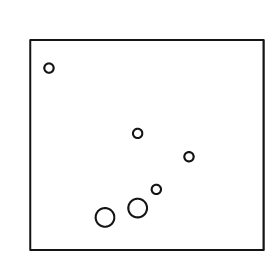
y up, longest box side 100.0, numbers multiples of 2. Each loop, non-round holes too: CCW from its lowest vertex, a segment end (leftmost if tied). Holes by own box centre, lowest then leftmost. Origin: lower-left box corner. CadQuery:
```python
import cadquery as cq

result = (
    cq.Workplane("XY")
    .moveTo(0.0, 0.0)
    .lineTo(100.0, 0.0)
    .lineTo(100.0, 90.0)
    .lineTo(0.0, 90.0)
    .close()
    .moveTo(32.0, 14.0)
    .circle(4.0)
    .moveTo(46.0, 18.0)
    .circle(4.0)
    .moveTo(54.0, 26.0)
    .circle(2.0)
    .moveTo(68.0, 40.0)
    .circle(2.0)
    .moveTo(46.0, 50.0)
    .circle(2.0)
    .moveTo(8.0, 78.0)
    .circle(2.0)
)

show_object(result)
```